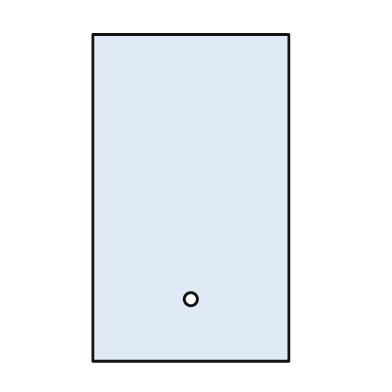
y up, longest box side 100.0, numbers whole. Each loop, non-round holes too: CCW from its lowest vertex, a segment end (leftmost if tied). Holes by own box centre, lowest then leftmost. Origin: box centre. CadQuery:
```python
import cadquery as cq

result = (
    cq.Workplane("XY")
    .moveTo(-30.0, -50.0)
    .lineTo(30.0, -50.0)
    .lineTo(30.0, 50.0)
    .lineTo(-30.0, 50.0)
    .close()
    .moveTo(0.0, -31.0)
    .circle(2.0)
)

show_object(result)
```